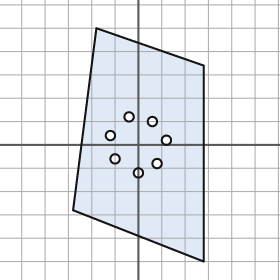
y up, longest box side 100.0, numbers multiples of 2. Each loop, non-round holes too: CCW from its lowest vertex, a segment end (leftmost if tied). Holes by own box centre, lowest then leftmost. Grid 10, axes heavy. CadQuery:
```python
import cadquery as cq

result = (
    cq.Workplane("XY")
    .moveTo(28.0, -50.0)
    .lineTo(28.0, 34.0)
    .lineTo(-18.0, 50.0)
    .lineTo(-28.0, -28.0)
    .close()
    .moveTo(0.0, -12.0)
    .circle(2.0)
    .moveTo(8.0, -8.0)
    .circle(2.0)
    .moveTo(-10.0, -6.0)
    .circle(2.0)
    .moveTo(12.0, 2.0)
    .circle(2.0)
    .moveTo(-12.0, 4.0)
    .circle(2.0)
    .moveTo(6.0, 10.0)
    .circle(2.0)
    .moveTo(-4.0, 12.0)
    .circle(2.0)
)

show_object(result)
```